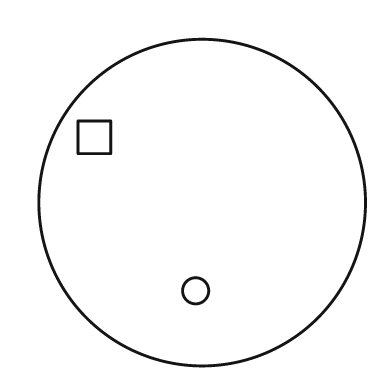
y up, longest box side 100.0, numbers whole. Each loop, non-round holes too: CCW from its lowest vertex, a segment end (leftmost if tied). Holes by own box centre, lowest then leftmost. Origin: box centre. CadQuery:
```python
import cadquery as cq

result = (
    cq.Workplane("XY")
    .moveTo(0.0, 0.0)
    .circle(50.0)
    .moveTo(-2.0, -27.0)
    .circle(4.0)
    .moveTo(-38.0, 15.0)
    .lineTo(-28.0, 15.0)
    .lineTo(-28.0, 25.0)
    .lineTo(-38.0, 25.0)
    .close()
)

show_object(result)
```